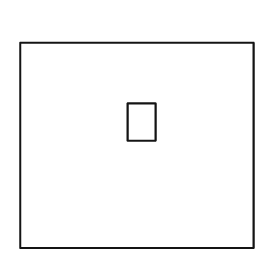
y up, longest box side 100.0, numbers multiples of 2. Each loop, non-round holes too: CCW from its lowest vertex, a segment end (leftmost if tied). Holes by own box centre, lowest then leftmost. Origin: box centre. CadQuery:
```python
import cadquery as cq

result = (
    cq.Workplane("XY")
    .moveTo(-50.0, -44.0)
    .lineTo(50.0, -44.0)
    .lineTo(50.0, 44.0)
    .lineTo(-50.0, 44.0)
    .close()
    .moveTo(-4.0, 2.0)
    .lineTo(8.0, 2.0)
    .lineTo(8.0, 18.0)
    .lineTo(-4.0, 18.0)
    .close()
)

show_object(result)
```